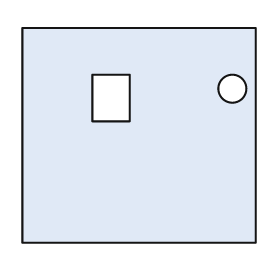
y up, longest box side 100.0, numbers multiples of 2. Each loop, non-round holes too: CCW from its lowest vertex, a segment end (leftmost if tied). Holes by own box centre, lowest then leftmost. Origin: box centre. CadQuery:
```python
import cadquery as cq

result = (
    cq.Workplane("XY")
    .moveTo(-50.0, -46.0)
    .lineTo(50.0, -46.0)
    .lineTo(50.0, 46.0)
    .lineTo(-50.0, 46.0)
    .close()
    .moveTo(-20.0, 6.0)
    .lineTo(-4.0, 6.0)
    .lineTo(-4.0, 26.0)
    .lineTo(-20.0, 26.0)
    .close()
    .moveTo(40.0, 20.0)
    .circle(6.0)
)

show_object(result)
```